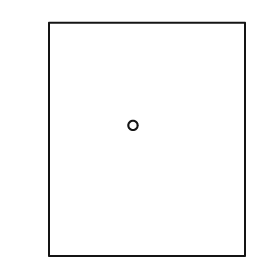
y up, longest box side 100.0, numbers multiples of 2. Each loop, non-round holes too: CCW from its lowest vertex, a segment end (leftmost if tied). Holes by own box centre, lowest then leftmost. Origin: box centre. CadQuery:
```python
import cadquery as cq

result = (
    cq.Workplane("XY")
    .moveTo(-42.0, -50.0)
    .lineTo(42.0, -50.0)
    .lineTo(42.0, 50.0)
    .lineTo(-42.0, 50.0)
    .close()
    .moveTo(-6.0, 6.0)
    .circle(2.0)
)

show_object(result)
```